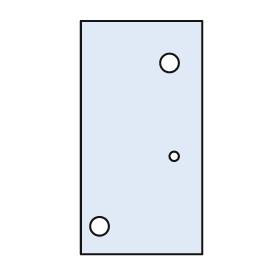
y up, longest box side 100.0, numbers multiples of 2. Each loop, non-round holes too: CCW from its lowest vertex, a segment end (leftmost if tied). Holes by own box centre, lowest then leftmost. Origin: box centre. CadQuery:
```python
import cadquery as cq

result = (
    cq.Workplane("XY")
    .moveTo(-26.0, -50.0)
    .lineTo(26.0, -50.0)
    .lineTo(26.0, 50.0)
    .lineTo(-26.0, 50.0)
    .close()
    .moveTo(-18.0, -38.0)
    .circle(4.0)
    .moveTo(14.0, -8.0)
    .circle(2.0)
    .moveTo(12.0, 32.0)
    .circle(4.0)
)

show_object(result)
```